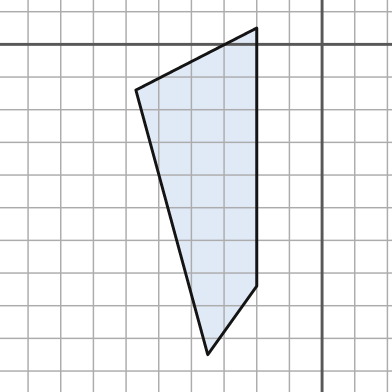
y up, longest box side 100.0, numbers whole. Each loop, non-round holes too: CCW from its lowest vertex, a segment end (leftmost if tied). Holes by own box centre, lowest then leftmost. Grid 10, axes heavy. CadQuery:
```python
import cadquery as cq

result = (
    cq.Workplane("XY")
    .moveTo(-35.0, -95.0)
    .lineTo(-20.0, -74.0)
    .lineTo(-20.0, 5.0)
    .lineTo(-57.0, -14.0)
    .close()
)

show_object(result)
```